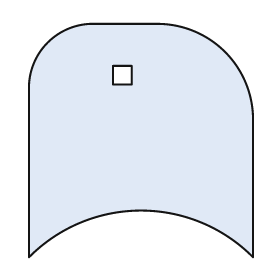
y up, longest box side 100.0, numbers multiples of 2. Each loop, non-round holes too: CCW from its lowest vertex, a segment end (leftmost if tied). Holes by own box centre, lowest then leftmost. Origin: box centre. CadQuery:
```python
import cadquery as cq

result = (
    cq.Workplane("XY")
    .moveTo(-48.0, -50.0)
    .threePointArc((0.0, -30.0), (48.0, -50.0))
    .lineTo(48.0, 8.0)
    .threePointArc((36.0, 38.0), (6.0, 50.0))
    .lineTo(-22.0, 50.0)
    .threePointArc((-40.0, 42.0), (-48.0, 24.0))
    .close()
    .moveTo(-12.0, 24.0)
    .lineTo(-4.0, 24.0)
    .lineTo(-4.0, 32.0)
    .lineTo(-12.0, 32.0)
    .close()
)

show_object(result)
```